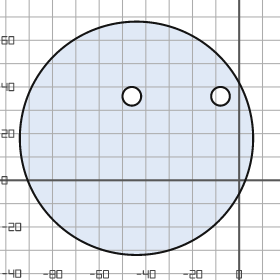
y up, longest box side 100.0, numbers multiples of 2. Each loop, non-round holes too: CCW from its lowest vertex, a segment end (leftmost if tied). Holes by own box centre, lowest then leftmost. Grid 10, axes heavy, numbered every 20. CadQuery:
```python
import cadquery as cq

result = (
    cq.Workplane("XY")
    .moveTo(-44.0, 18.0)
    .circle(50.0)
    .moveTo(-46.0, 36.0)
    .circle(4.0)
    .moveTo(-8.0, 36.0)
    .circle(4.0)
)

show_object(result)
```